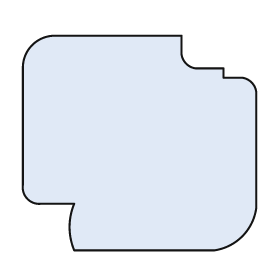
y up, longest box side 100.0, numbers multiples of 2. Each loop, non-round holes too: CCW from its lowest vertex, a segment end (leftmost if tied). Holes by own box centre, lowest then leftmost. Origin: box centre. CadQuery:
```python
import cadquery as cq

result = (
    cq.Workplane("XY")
    .moveTo(-28.0, -46.0)
    .lineTo(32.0, -46.0)
    .threePointArc((44.0, -40.0), (50.0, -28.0))
    .lineTo(50.0, 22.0)
    .threePointArc((48.0, 26.0), (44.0, 28.0))
    .lineTo(36.0, 28.0)
    .lineTo(36.0, 32.0)
    .lineTo(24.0, 32.0)
    .threePointArc((20.0, 34.0), (18.0, 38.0))
    .lineTo(18.0, 46.0)
    .lineTo(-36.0, 46.0)
    .threePointArc((-46.0, 42.0), (-50.0, 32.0))
    .lineTo(-50.0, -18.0)
    .threePointArc((-48.0, -24.0), (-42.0, -26.0))
    .lineTo(-28.0, -26.0)
    .threePointArc((-30.0, -36.0), (-28.0, -46.0))
    .close()
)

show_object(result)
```